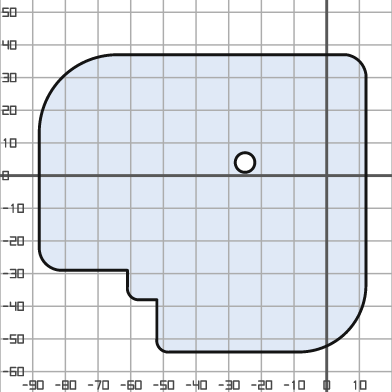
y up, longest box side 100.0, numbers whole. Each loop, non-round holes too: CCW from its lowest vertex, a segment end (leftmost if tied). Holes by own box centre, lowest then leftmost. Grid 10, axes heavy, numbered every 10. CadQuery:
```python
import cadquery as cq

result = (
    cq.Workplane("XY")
    .moveTo(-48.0, -54.0)
    .lineTo(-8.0, -54.0)
    .threePointArc((6.0, -48.0), (12.0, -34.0))
    .lineTo(12.0, 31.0)
    .threePointArc((10.0, 35.0), (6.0, 37.0))
    .lineTo(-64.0, 37.0)
    .threePointArc((-81.0, 30.0), (-88.0, 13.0))
    .lineTo(-88.0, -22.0)
    .threePointArc((-86.0, -27.0), (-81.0, -29.0))
    .lineTo(-61.0, -29.0)
    .lineTo(-61.0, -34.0)
    .threePointArc((-60.0, -37.0), (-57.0, -38.0))
    .lineTo(-52.0, -38.0)
    .lineTo(-52.0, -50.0)
    .threePointArc((-51.0, -53.0), (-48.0, -54.0))
    .close()
    .moveTo(-25.0, 4.0)
    .circle(3.0)
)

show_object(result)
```